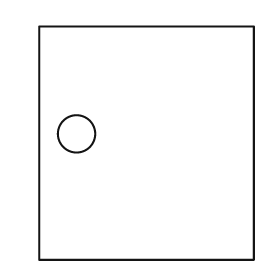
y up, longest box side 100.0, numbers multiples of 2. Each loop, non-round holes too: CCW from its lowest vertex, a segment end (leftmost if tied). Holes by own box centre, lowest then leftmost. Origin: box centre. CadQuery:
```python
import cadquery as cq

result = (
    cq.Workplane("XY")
    .moveTo(-46.0, -50.0)
    .lineTo(46.0, -50.0)
    .lineTo(46.0, 50.0)
    .lineTo(-46.0, 50.0)
    .close()
    .moveTo(-30.0, 4.0)
    .circle(8.0)
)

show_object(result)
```